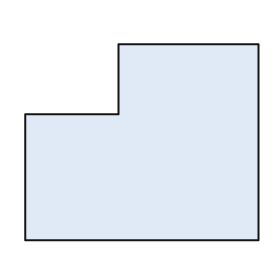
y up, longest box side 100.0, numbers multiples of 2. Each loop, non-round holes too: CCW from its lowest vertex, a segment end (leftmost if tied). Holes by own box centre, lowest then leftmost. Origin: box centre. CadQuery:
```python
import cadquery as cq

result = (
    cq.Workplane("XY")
    .moveTo(-50.0, -42.0)
    .lineTo(50.0, -42.0)
    .lineTo(50.0, 42.0)
    .lineTo(-10.0, 42.0)
    .lineTo(-10.0, 12.0)
    .lineTo(-50.0, 12.0)
    .close()
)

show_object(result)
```